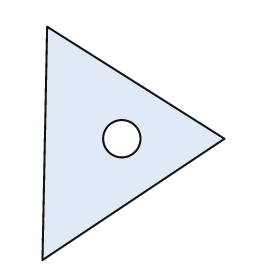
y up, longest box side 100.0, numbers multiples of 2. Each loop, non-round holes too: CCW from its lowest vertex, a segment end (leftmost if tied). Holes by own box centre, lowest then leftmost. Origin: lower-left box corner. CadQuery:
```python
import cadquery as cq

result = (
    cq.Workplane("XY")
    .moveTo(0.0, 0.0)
    .lineTo(78.0, 52.0)
    .lineTo(2.0, 100.0)
    .close()
    .moveTo(34.0, 52.0)
    .circle(8.0)
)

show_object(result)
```